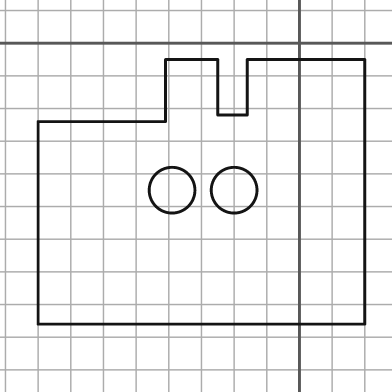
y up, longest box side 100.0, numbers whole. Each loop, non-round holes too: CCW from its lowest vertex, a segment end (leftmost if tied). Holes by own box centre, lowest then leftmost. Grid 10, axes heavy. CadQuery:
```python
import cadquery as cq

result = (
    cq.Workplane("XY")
    .moveTo(-80.0, -86.0)
    .lineTo(20.0, -86.0)
    .lineTo(20.0, -5.0)
    .lineTo(-16.0, -5.0)
    .lineTo(-16.0, -22.0)
    .lineTo(-25.0, -22.0)
    .lineTo(-25.0, -5.0)
    .lineTo(-41.0, -5.0)
    .lineTo(-41.0, -24.0)
    .lineTo(-80.0, -24.0)
    .close()
    .moveTo(-39.0, -45.0)
    .circle(7.0)
    .moveTo(-20.0, -45.0)
    .circle(7.0)
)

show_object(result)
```